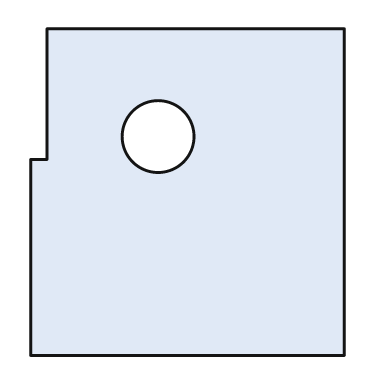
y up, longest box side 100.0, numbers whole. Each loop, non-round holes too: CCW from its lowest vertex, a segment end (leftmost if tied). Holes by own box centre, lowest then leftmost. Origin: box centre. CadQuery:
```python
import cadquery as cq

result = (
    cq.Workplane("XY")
    .moveTo(-48.0, -50.0)
    .lineTo(48.0, -50.0)
    .lineTo(48.0, 50.0)
    .lineTo(-43.0, 50.0)
    .lineTo(-43.0, 10.0)
    .lineTo(-48.0, 10.0)
    .close()
    .moveTo(-9.0, 17.0)
    .circle(11.0)
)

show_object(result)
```